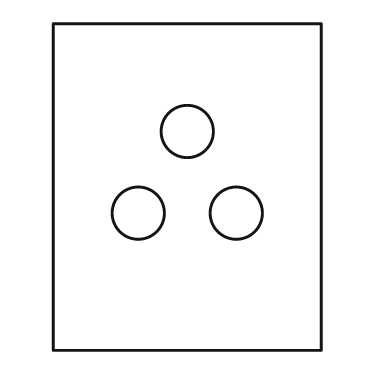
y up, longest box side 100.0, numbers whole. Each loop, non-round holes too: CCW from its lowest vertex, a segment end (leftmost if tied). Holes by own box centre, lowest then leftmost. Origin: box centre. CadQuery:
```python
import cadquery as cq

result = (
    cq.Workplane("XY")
    .moveTo(-41.0, -50.0)
    .lineTo(41.0, -50.0)
    .lineTo(41.0, 50.0)
    .lineTo(-41.0, 50.0)
    .close()
    .moveTo(-15.0, -8.0)
    .circle(8.0)
    .moveTo(15.0, -8.0)
    .circle(8.0)
    .moveTo(0.0, 17.0)
    .circle(8.0)
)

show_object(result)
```